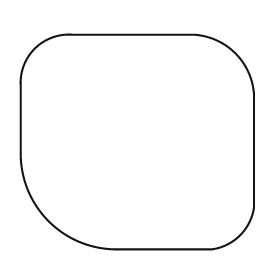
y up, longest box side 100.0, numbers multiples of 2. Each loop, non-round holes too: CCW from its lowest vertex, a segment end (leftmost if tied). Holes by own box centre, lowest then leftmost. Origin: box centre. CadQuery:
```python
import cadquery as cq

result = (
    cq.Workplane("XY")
    .moveTo(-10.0, -46.0)
    .lineTo(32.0, -46.0)
    .threePointArc((44.0, -40.0), (50.0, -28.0))
    .lineTo(50.0, 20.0)
    .threePointArc((42.0, 38.0), (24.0, 46.0))
    .lineTo(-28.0, 46.0)
    .threePointArc((-44.0, 40.0), (-50.0, 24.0))
    .lineTo(-50.0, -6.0)
    .threePointArc((-38.0, -34.0), (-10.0, -46.0))
    .close()
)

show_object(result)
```